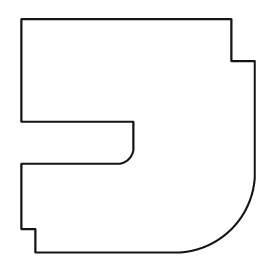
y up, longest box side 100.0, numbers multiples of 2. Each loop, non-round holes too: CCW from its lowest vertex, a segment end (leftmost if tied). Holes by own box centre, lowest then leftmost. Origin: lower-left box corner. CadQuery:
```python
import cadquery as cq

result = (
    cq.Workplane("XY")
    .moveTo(6.0, 0.0)
    .lineTo(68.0, 0.0)
    .threePointArc((90.0, 10.0), (100.0, 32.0))
    .lineTo(100.0, 82.0)
    .lineTo(90.0, 82.0)
    .lineTo(90.0, 100.0)
    .lineTo(0.0, 100.0)
    .lineTo(0.0, 56.0)
    .lineTo(48.0, 56.0)
    .lineTo(48.0, 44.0)
    .threePointArc((46.0, 40.0), (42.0, 38.0))
    .lineTo(0.0, 38.0)
    .lineTo(0.0, 10.0)
    .lineTo(6.0, 10.0)
    .close()
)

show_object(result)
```